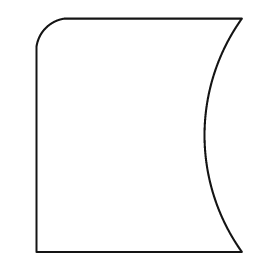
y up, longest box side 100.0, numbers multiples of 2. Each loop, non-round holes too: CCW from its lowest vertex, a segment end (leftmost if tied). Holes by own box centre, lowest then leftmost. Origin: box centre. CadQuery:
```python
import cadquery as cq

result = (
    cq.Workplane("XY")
    .moveTo(-44.0, -50.0)
    .lineTo(44.0, -50.0)
    .threePointArc((28.0, 0.0), (44.0, 50.0))
    .lineTo(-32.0, 50.0)
    .threePointArc((-40.0, 46.0), (-44.0, 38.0))
    .close()
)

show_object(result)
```